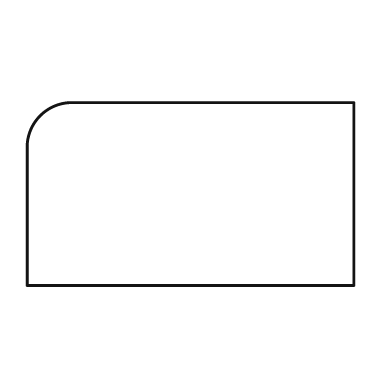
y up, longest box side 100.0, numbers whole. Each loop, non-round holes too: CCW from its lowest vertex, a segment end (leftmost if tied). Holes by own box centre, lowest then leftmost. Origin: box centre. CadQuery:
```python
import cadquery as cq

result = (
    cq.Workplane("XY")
    .moveTo(-50.0, -28.0)
    .lineTo(50.0, -28.0)
    .lineTo(50.0, 28.0)
    .lineTo(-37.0, 28.0)
    .threePointArc((-46.0, 24.0), (-50.0, 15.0))
    .close()
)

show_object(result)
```